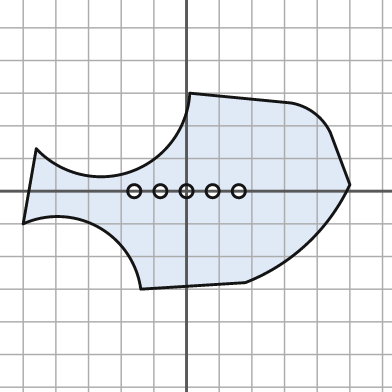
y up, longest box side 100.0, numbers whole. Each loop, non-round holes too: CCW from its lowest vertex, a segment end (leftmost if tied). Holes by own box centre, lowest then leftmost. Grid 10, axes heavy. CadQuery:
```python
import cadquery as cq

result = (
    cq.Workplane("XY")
    .moveTo(-14.0, -30.0)
    .lineTo(18.0, -28.0)
    .threePointArc((37.0, -16.0), (50.0, 2.0))
    .lineTo(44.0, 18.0)
    .threePointArc((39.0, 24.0), (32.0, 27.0))
    .lineTo(1.0, 30.0)
    .threePointArc((-17.0, 6.0), (-46.0, 13.0))
    .lineTo(-50.0, -10.0)
    .threePointArc((-27.0, -11.0), (-14.0, -30.0))
    .close()
    .moveTo(-16.0, 0.0)
    .circle(2.0)
    .moveTo(-8.0, 0.0)
    .circle(2.0)
    .moveTo(0.0, 0.0)
    .circle(2.0)
    .moveTo(8.0, 0.0)
    .circle(2.0)
    .moveTo(16.0, 0.0)
    .circle(2.0)
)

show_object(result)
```